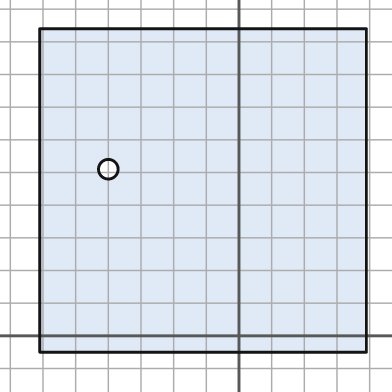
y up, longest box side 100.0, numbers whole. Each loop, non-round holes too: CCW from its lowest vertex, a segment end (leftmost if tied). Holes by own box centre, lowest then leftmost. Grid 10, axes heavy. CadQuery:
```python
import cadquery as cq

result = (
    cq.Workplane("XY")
    .moveTo(-61.0, -5.0)
    .lineTo(39.0, -5.0)
    .lineTo(39.0, 94.0)
    .lineTo(-61.0, 94.0)
    .close()
    .moveTo(-40.0, 51.0)
    .circle(3.0)
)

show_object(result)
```